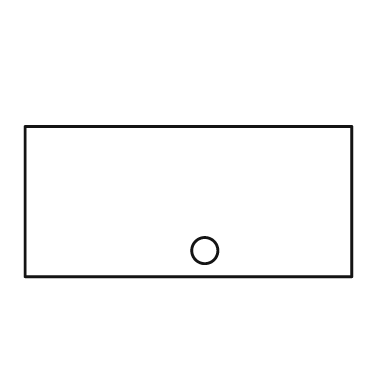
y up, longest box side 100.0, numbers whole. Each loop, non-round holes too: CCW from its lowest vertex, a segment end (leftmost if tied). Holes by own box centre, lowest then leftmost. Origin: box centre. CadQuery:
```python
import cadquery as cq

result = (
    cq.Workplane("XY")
    .moveTo(-50.0, -23.0)
    .lineTo(50.0, -23.0)
    .lineTo(50.0, 23.0)
    .lineTo(-50.0, 23.0)
    .close()
    .moveTo(5.0, -15.0)
    .circle(4.0)
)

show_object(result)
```